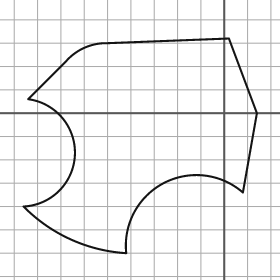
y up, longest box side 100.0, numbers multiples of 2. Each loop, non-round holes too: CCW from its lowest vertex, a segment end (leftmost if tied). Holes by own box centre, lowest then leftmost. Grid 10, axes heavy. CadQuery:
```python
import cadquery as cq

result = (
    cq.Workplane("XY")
    .moveTo(-42.0, -60.0)
    .threePointArc((-26.0, -30.0), (8.0, -34.0))
    .lineTo(14.0, 0.0)
    .lineTo(2.0, 32.0)
    .lineTo(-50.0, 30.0)
    .threePointArc((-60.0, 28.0), (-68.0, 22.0))
    .lineTo(-84.0, 6.0)
    .threePointArc((-64.0, -18.0), (-86.0, -40.0))
    .threePointArc((-66.0, -54.0), (-42.0, -60.0))
    .close()
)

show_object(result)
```